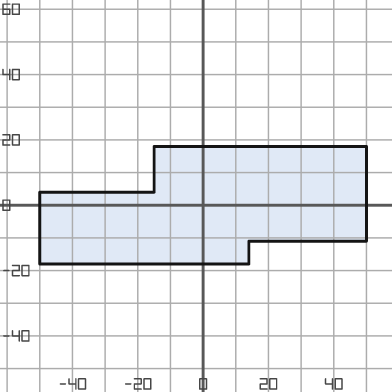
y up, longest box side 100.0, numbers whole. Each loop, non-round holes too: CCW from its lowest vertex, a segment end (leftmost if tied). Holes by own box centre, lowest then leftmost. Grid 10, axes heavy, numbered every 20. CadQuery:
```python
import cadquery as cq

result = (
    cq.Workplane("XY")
    .moveTo(-50.0, -18.0)
    .lineTo(14.0, -18.0)
    .lineTo(14.0, -11.0)
    .lineTo(50.0, -11.0)
    .lineTo(50.0, 18.0)
    .lineTo(-15.0, 18.0)
    .lineTo(-15.0, 4.0)
    .lineTo(-50.0, 4.0)
    .close()
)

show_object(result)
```